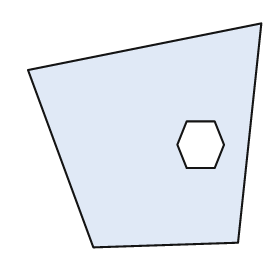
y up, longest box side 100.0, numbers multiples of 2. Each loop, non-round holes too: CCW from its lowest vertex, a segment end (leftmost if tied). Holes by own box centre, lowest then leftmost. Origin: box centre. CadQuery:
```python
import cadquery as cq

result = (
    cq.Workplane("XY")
    .moveTo(-22.0, -48.0)
    .lineTo(40.0, -46.0)
    .lineTo(50.0, 48.0)
    .lineTo(-50.0, 28.0)
    .close()
    .moveTo(18.0, -14.0)
    .lineTo(30.0, -14.0)
    .lineTo(34.0, -4.0)
    .lineTo(30.0, 6.0)
    .lineTo(18.0, 6.0)
    .lineTo(14.0, -4.0)
    .close()
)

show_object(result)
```